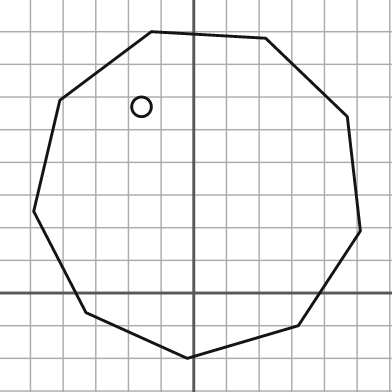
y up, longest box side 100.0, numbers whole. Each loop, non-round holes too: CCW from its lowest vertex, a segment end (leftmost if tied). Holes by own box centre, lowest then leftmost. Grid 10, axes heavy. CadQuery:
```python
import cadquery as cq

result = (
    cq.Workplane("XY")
    .moveTo(-2.0, -20.0)
    .lineTo(32.0, -10.0)
    .lineTo(51.0, 19.0)
    .lineTo(47.0, 54.0)
    .lineTo(22.0, 78.0)
    .lineTo(-13.0, 80.0)
    .lineTo(-41.0, 59.0)
    .lineTo(-49.0, 25.0)
    .lineTo(-33.0, -6.0)
    .close()
    .moveTo(-16.0, 57.0)
    .circle(3.0)
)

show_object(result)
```